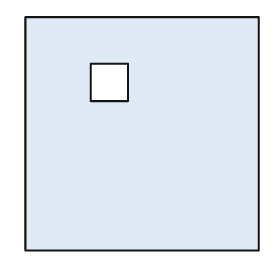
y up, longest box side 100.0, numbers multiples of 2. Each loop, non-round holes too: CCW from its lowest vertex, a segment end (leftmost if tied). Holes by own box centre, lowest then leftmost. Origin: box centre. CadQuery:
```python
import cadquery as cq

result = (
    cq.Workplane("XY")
    .moveTo(-50.0, -50.0)
    .lineTo(50.0, -50.0)
    .lineTo(50.0, 50.0)
    .lineTo(-50.0, 50.0)
    .close()
    .moveTo(-22.0, 14.0)
    .lineTo(-6.0, 14.0)
    .lineTo(-6.0, 30.0)
    .lineTo(-22.0, 30.0)
    .close()
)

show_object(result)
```